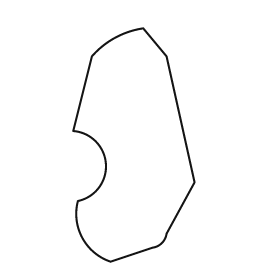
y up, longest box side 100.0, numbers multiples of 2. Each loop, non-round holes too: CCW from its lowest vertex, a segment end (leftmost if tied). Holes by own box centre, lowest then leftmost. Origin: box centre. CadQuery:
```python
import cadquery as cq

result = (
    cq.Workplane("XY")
    .moveTo(-10.0, -50.0)
    .lineTo(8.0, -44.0)
    .threePointArc((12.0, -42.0), (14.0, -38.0))
    .lineTo(26.0, -16.0)
    .lineTo(14.0, 38.0)
    .lineTo(4.0, 50.0)
    .threePointArc((-8.0, 46.0), (-18.0, 38.0))
    .lineTo(-26.0, 6.0)
    .threePointArc((-12.0, -8.0), (-24.0, -24.0))
    .threePointArc((-22.0, -40.0), (-10.0, -50.0))
    .close()
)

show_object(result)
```